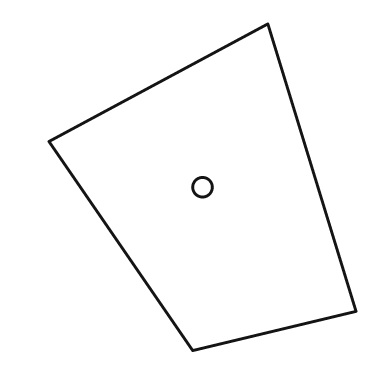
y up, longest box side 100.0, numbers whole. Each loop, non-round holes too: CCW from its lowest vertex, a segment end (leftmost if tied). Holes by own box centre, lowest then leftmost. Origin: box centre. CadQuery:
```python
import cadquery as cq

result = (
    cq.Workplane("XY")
    .moveTo(-3.0, -50.0)
    .lineTo(47.0, -38.0)
    .lineTo(20.0, 50.0)
    .lineTo(-47.0, 14.0)
    .close()
    .moveTo(0.0, 0.0)
    .circle(3.0)
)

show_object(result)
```